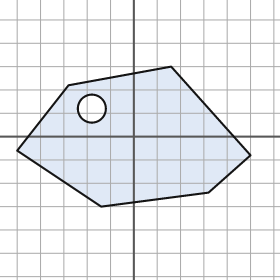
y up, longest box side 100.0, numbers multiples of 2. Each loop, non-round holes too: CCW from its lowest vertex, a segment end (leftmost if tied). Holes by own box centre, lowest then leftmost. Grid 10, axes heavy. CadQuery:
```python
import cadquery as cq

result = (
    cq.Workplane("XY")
    .moveTo(-14.0, -30.0)
    .lineTo(32.0, -24.0)
    .lineTo(50.0, -8.0)
    .lineTo(16.0, 30.0)
    .lineTo(-28.0, 22.0)
    .lineTo(-50.0, -6.0)
    .close()
    .moveTo(-18.0, 12.0)
    .circle(6.0)
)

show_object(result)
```